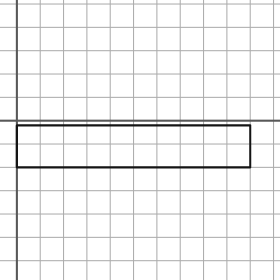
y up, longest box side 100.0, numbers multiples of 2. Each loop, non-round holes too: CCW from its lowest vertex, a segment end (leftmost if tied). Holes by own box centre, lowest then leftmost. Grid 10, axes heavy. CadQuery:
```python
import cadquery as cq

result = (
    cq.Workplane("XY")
    .moveTo(0.0, -20.0)
    .lineTo(100.0, -20.0)
    .lineTo(100.0, -2.0)
    .lineTo(0.0, -2.0)
    .close()
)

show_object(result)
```